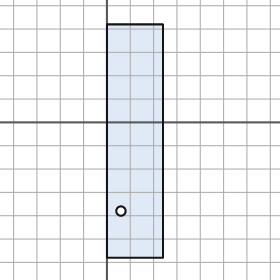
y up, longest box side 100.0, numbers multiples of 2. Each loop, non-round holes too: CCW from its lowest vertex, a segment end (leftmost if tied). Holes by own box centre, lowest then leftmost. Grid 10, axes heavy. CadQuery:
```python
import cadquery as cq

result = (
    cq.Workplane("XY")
    .moveTo(0.0, -58.0)
    .lineTo(24.0, -58.0)
    .lineTo(24.0, 42.0)
    .lineTo(0.0, 42.0)
    .close()
    .moveTo(6.0, -38.0)
    .circle(2.0)
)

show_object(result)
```